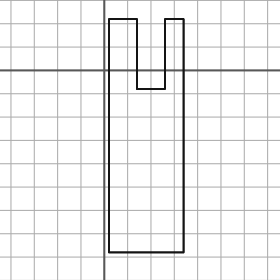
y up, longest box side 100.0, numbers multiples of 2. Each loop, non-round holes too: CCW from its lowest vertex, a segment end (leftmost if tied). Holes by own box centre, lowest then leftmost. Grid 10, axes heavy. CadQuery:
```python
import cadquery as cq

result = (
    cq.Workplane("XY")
    .moveTo(2.0, -78.0)
    .lineTo(34.0, -78.0)
    .lineTo(34.0, 22.0)
    .lineTo(26.0, 22.0)
    .lineTo(26.0, -8.0)
    .lineTo(14.0, -8.0)
    .lineTo(14.0, 22.0)
    .lineTo(2.0, 22.0)
    .close()
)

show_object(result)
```